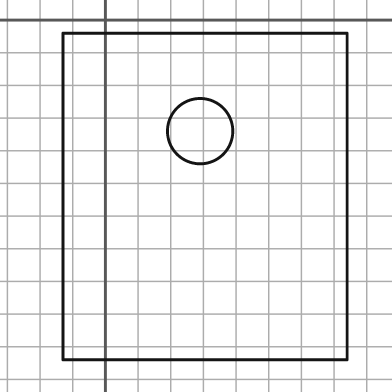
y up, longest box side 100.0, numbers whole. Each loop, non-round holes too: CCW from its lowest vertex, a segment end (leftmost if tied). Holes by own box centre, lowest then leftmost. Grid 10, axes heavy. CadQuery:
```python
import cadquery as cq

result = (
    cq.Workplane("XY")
    .moveTo(-13.0, -104.0)
    .lineTo(74.0, -104.0)
    .lineTo(74.0, -4.0)
    .lineTo(-13.0, -4.0)
    .close()
    .moveTo(29.0, -34.0)
    .circle(10.0)
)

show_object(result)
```